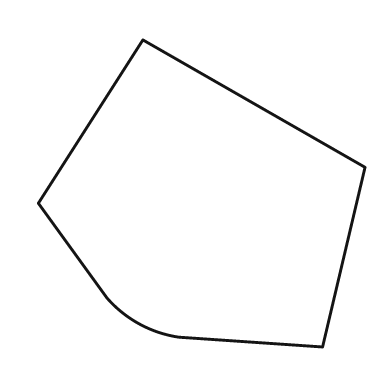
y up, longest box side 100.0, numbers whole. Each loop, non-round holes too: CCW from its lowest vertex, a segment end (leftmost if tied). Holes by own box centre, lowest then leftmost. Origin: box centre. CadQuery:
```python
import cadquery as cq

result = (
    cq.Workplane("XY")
    .moveTo(37.0, -47.0)
    .lineTo(50.0, 8.0)
    .lineTo(-18.0, 47.0)
    .lineTo(-50.0, -3.0)
    .lineTo(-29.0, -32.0)
    .threePointArc((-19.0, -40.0), (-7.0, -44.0))
    .close()
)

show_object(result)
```